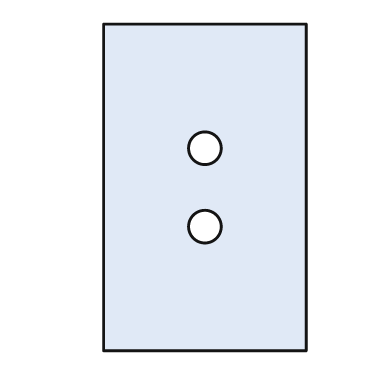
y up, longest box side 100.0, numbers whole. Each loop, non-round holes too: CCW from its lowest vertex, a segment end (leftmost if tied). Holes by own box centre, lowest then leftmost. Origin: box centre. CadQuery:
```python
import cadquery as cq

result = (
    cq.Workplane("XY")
    .moveTo(-31.0, -50.0)
    .lineTo(31.0, -50.0)
    .lineTo(31.0, 50.0)
    .lineTo(-31.0, 50.0)
    .close()
    .moveTo(0.0, -12.0)
    .circle(5.0)
    .moveTo(0.0, 12.0)
    .circle(5.0)
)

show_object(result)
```